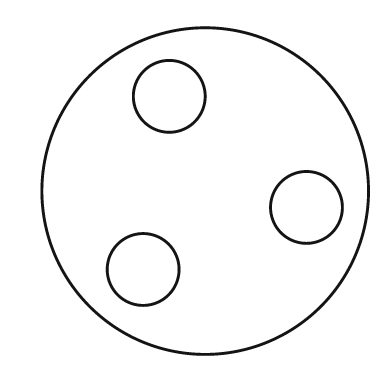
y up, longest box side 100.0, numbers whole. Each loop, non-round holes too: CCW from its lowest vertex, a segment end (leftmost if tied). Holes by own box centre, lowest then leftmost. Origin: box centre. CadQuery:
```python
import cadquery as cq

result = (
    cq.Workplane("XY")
    .moveTo(0.0, 0.0)
    .circle(50.0)
    .moveTo(-19.0, -24.0)
    .circle(11.0)
    .moveTo(31.0, -5.0)
    .circle(11.0)
    .moveTo(-11.0, 29.0)
    .circle(11.0)
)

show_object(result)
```